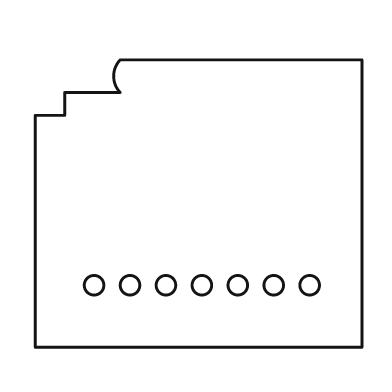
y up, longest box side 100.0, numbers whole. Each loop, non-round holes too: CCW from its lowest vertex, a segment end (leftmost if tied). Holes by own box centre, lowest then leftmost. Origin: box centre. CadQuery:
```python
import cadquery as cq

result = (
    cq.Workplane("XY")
    .moveTo(-50.0, -44.0)
    .lineTo(50.0, -44.0)
    .lineTo(50.0, 44.0)
    .lineTo(-24.0, 44.0)
    .threePointArc((-26.0, 39.0), (-24.0, 34.0))
    .lineTo(-41.0, 34.0)
    .lineTo(-41.0, 27.0)
    .lineTo(-50.0, 27.0)
    .close()
    .moveTo(-32.0, -25.0)
    .circle(3.0)
    .moveTo(-21.0, -25.0)
    .circle(3.0)
    .moveTo(-10.0, -25.0)
    .circle(3.0)
    .moveTo(1.0, -25.0)
    .circle(3.0)
    .moveTo(12.0, -25.0)
    .circle(3.0)
    .moveTo(23.0, -25.0)
    .circle(3.0)
    .moveTo(34.0, -25.0)
    .circle(3.0)
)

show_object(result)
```